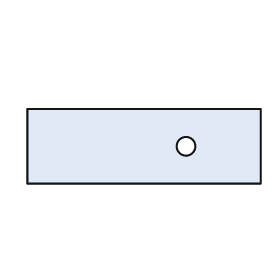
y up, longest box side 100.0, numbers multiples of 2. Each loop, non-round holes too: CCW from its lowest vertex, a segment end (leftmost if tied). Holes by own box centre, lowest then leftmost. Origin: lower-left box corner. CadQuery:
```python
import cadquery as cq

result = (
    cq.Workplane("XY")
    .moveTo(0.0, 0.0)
    .lineTo(100.0, 0.0)
    .lineTo(100.0, 32.0)
    .lineTo(0.0, 32.0)
    .close()
    .moveTo(68.0, 16.0)
    .circle(4.0)
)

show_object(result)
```